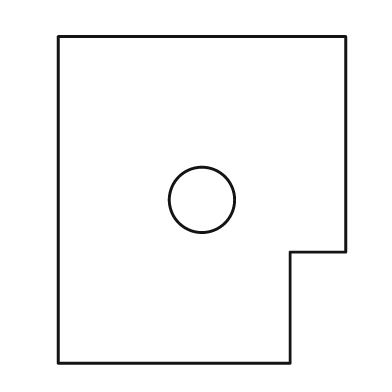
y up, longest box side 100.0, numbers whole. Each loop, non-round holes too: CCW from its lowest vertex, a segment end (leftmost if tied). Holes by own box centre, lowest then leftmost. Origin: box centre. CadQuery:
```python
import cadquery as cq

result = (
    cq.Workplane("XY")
    .moveTo(-44.0, -50.0)
    .lineTo(27.0, -50.0)
    .lineTo(27.0, -16.0)
    .lineTo(44.0, -16.0)
    .lineTo(44.0, 50.0)
    .lineTo(-44.0, 50.0)
    .close()
    .moveTo(0.0, 0.0)
    .circle(10.0)
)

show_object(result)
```